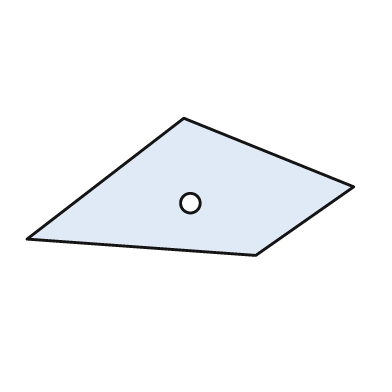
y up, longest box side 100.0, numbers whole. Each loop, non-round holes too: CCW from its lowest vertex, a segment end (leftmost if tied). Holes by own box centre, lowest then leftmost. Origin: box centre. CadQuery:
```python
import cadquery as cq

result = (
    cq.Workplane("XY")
    .moveTo(20.0, -21.0)
    .lineTo(50.0, 0.0)
    .lineTo(-2.0, 21.0)
    .lineTo(-50.0, -16.0)
    .close()
    .moveTo(0.0, -5.0)
    .circle(3.0)
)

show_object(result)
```